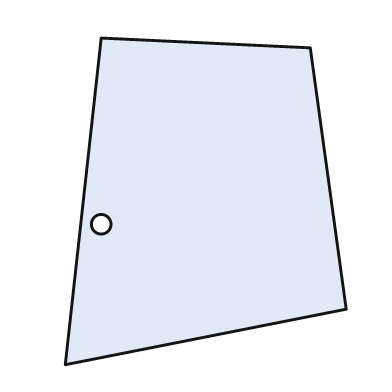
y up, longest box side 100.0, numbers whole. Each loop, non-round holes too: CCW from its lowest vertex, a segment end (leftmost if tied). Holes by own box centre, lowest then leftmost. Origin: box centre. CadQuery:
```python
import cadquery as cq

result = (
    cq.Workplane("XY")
    .moveTo(-43.0, -50.0)
    .lineTo(43.0, -33.0)
    .lineTo(32.0, 47.0)
    .lineTo(-32.0, 50.0)
    .close()
    .moveTo(-32.0, -7.0)
    .circle(3.0)
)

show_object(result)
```